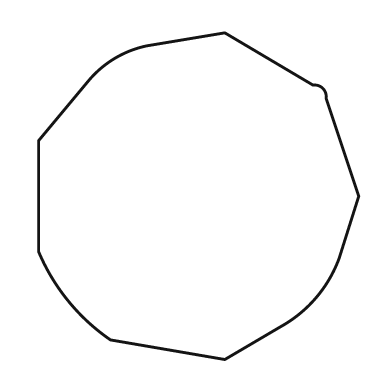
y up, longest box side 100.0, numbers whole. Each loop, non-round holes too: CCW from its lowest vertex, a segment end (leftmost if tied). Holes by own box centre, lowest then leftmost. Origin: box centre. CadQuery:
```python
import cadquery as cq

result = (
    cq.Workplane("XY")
    .moveTo(8.0, -50.0)
    .lineTo(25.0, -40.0)
    .threePointArc((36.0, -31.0), (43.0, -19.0))
    .lineTo(49.0, 0.0)
    .lineTo(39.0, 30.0)
    .threePointArc((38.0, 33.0), (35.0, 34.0))
    .lineTo(8.0, 50.0)
    .lineTo(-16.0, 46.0)
    .threePointArc((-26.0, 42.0), (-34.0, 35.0))
    .lineTo(-49.0, 17.0)
    .lineTo(-49.0, -17.0)
    .threePointArc((-40.0, -32.0), (-27.0, -44.0))
    .close()
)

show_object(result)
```